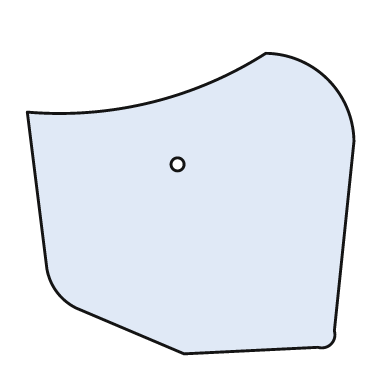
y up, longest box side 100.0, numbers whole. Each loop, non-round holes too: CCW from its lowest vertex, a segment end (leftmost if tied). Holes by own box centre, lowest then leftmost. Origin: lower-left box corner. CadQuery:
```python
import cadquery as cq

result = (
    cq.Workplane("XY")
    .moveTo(48.0, 0.0)
    .lineTo(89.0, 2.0)
    .threePointArc((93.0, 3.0), (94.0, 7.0))
    .lineTo(100.0, 65.0)
    .threePointArc((92.0, 84.0), (73.0, 92.0))
    .threePointArc((38.0, 77.0), (0.0, 74.0))
    .lineTo(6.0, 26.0)
    .threePointArc((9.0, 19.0), (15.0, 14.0))
    .close()
    .moveTo(46.0, 58.0)
    .circle(2.0)
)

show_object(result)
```